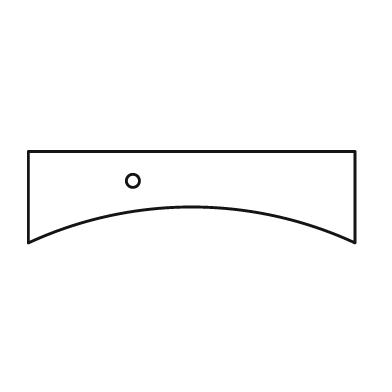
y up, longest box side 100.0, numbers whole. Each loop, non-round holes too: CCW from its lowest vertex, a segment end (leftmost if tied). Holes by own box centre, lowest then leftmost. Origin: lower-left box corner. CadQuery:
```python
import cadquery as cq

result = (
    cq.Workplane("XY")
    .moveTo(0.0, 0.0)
    .threePointArc((50.0, 11.0), (100.0, 0.0))
    .lineTo(100.0, 28.0)
    .lineTo(0.0, 28.0)
    .close()
    .moveTo(32.0, 19.0)
    .circle(2.0)
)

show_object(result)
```